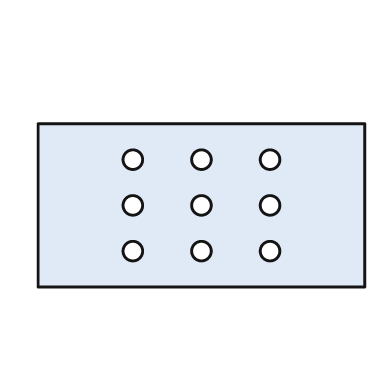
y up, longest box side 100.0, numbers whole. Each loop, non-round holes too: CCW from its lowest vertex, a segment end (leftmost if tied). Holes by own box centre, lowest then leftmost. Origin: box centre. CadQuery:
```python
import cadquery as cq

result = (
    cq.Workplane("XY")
    .moveTo(-50.0, -25.0)
    .lineTo(50.0, -25.0)
    .lineTo(50.0, 25.0)
    .lineTo(-50.0, 25.0)
    .close()
    .moveTo(-21.0, -14.0)
    .circle(3.0)
    .moveTo(0.0, -14.0)
    .circle(3.0)
    .moveTo(21.0, -14.0)
    .circle(3.0)
    .moveTo(-21.0, 0.0)
    .circle(3.0)
    .moveTo(0.0, 0.0)
    .circle(3.0)
    .moveTo(21.0, 0.0)
    .circle(3.0)
    .moveTo(-21.0, 14.0)
    .circle(3.0)
    .moveTo(0.0, 14.0)
    .circle(3.0)
    .moveTo(21.0, 14.0)
    .circle(3.0)
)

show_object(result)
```